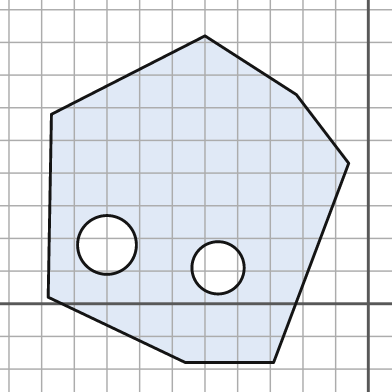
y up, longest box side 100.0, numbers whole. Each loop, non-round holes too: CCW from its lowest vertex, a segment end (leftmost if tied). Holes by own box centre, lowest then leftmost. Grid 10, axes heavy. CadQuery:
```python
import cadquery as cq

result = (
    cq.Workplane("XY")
    .moveTo(-56.0, -18.0)
    .lineTo(-29.0, -18.0)
    .lineTo(-6.0, 43.0)
    .lineTo(-22.0, 64.0)
    .lineTo(-50.0, 82.0)
    .lineTo(-97.0, 58.0)
    .lineTo(-98.0, 2.0)
    .close()
    .moveTo(-46.0, 11.0)
    .circle(8.0)
    .moveTo(-80.0, 18.0)
    .circle(9.0)
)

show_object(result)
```